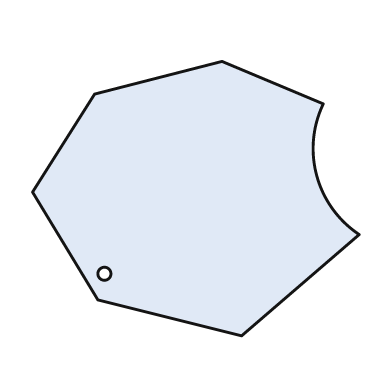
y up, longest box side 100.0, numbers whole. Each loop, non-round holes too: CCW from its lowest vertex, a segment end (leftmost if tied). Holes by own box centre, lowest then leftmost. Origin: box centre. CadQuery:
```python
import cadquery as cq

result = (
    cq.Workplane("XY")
    .moveTo(14.0, -42.0)
    .lineTo(50.0, -11.0)
    .threePointArc((37.0, 7.0), (39.0, 29.0))
    .lineTo(8.0, 42.0)
    .lineTo(-31.0, 32.0)
    .lineTo(-50.0, 2.0)
    .lineTo(-30.0, -31.0)
    .close()
    .moveTo(-28.0, -23.0)
    .circle(2.0)
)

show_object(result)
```